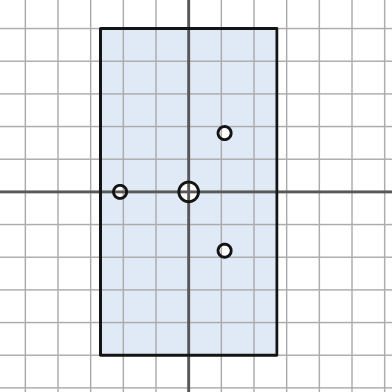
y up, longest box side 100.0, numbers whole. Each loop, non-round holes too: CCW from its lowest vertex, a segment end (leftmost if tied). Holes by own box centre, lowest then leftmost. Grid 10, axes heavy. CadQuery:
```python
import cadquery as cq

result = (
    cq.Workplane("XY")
    .moveTo(-27.0, -50.0)
    .lineTo(27.0, -50.0)
    .lineTo(27.0, 50.0)
    .lineTo(-27.0, 50.0)
    .close()
    .moveTo(11.0, -18.0)
    .circle(2.0)
    .moveTo(-21.0, 0.0)
    .circle(2.0)
    .moveTo(0.0, 0.0)
    .circle(3.0)
    .moveTo(11.0, 18.0)
    .circle(2.0)
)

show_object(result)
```